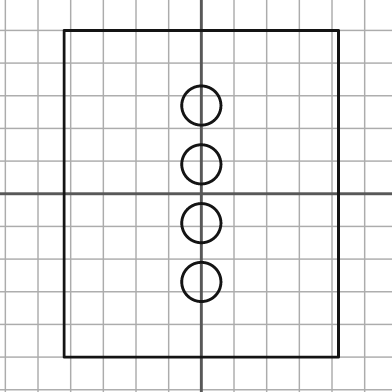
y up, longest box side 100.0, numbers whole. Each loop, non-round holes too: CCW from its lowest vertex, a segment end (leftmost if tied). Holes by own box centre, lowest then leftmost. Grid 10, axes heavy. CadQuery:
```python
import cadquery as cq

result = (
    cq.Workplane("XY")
    .moveTo(-42.0, -50.0)
    .lineTo(42.0, -50.0)
    .lineTo(42.0, 50.0)
    .lineTo(-42.0, 50.0)
    .close()
    .moveTo(0.0, -27.0)
    .circle(6.0)
    .moveTo(0.0, -9.0)
    .circle(6.0)
    .moveTo(0.0, 9.0)
    .circle(6.0)
    .moveTo(0.0, 27.0)
    .circle(6.0)
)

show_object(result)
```